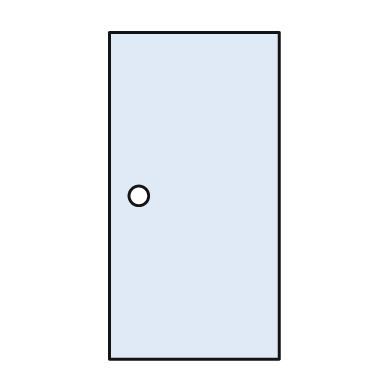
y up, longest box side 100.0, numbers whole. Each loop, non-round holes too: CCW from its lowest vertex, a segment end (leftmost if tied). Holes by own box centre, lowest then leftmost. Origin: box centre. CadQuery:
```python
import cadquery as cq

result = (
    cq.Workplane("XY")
    .moveTo(-26.0, -50.0)
    .lineTo(26.0, -50.0)
    .lineTo(26.0, 50.0)
    .lineTo(-26.0, 50.0)
    .close()
    .moveTo(-17.0, 0.0)
    .circle(3.0)
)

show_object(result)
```